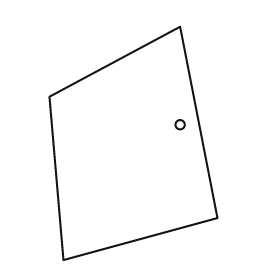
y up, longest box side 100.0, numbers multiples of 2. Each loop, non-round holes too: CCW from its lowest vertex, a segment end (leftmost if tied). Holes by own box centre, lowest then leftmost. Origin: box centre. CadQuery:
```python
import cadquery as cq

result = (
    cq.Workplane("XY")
    .moveTo(-30.0, -50.0)
    .lineTo(36.0, -32.0)
    .lineTo(20.0, 50.0)
    .lineTo(-36.0, 20.0)
    .close()
    .moveTo(20.0, 8.0)
    .circle(2.0)
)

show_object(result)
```